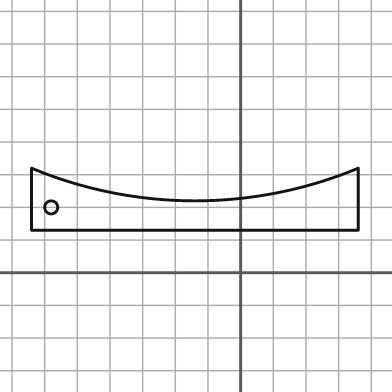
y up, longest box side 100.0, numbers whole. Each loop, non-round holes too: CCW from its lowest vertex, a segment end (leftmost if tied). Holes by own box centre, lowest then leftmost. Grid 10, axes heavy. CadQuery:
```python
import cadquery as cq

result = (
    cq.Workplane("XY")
    .moveTo(-64.0, 13.0)
    .lineTo(36.0, 13.0)
    .lineTo(36.0, 32.0)
    .threePointArc((-14.0, 22.0), (-64.0, 32.0))
    .close()
    .moveTo(-58.0, 20.0)
    .circle(2.0)
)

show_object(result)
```